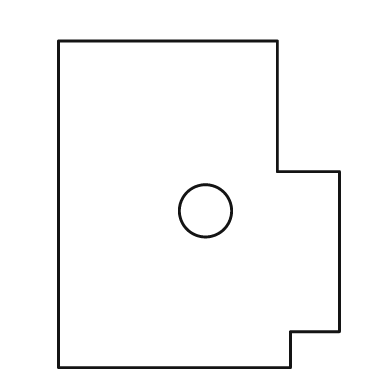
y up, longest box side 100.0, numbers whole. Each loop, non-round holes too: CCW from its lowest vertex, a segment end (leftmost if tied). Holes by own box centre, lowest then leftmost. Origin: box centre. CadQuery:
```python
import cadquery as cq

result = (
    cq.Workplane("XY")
    .moveTo(-43.0, -50.0)
    .lineTo(28.0, -50.0)
    .lineTo(28.0, -39.0)
    .lineTo(43.0, -39.0)
    .lineTo(43.0, 10.0)
    .lineTo(24.0, 10.0)
    .lineTo(24.0, 50.0)
    .lineTo(-43.0, 50.0)
    .close()
    .moveTo(2.0, -2.0)
    .circle(8.0)
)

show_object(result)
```